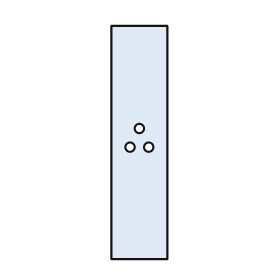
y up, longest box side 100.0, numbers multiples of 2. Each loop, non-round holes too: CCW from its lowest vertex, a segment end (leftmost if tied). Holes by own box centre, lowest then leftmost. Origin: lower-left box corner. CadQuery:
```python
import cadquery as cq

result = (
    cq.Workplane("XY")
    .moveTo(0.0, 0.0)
    .lineTo(24.0, 0.0)
    .lineTo(24.0, 100.0)
    .lineTo(0.0, 100.0)
    .close()
    .moveTo(8.0, 48.0)
    .circle(2.0)
    .moveTo(16.0, 48.0)
    .circle(2.0)
    .moveTo(12.0, 56.0)
    .circle(2.0)
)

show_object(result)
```